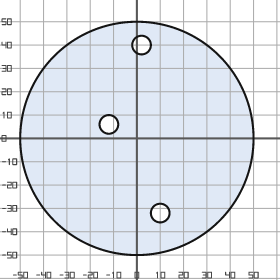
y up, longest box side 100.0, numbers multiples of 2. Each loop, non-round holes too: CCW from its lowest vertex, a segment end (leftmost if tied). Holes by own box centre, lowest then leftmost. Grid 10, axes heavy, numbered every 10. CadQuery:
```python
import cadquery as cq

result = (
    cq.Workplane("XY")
    .moveTo(0.0, 0.0)
    .circle(50.0)
    .moveTo(10.0, -32.0)
    .circle(4.0)
    .moveTo(-12.0, 6.0)
    .circle(4.0)
    .moveTo(2.0, 40.0)
    .circle(4.0)
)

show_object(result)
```